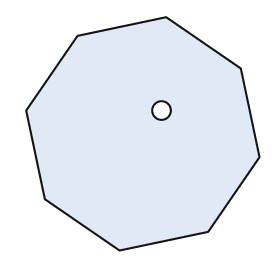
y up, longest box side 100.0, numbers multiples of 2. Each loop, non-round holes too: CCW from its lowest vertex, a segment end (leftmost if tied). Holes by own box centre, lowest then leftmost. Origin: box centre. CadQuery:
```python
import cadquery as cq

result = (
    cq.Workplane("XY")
    .moveTo(-10.0, -50.0)
    .lineTo(28.0, -42.0)
    .lineTo(50.0, -10.0)
    .lineTo(42.0, 28.0)
    .lineTo(10.0, 50.0)
    .lineTo(-28.0, 42.0)
    .lineTo(-50.0, 10.0)
    .lineTo(-42.0, -28.0)
    .close()
    .moveTo(8.0, 10.0)
    .circle(4.0)
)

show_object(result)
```